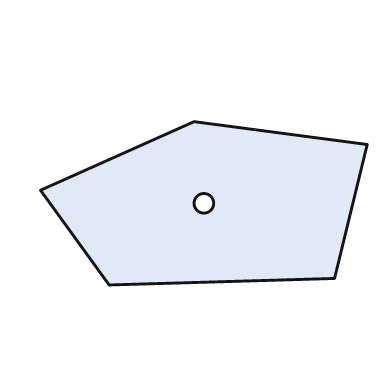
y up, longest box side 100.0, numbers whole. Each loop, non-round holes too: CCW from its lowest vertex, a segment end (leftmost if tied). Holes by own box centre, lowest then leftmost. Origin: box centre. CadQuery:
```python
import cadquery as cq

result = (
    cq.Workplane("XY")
    .moveTo(-29.0, -25.0)
    .lineTo(40.0, -23.0)
    .lineTo(50.0, 18.0)
    .lineTo(-3.0, 25.0)
    .lineTo(-50.0, 4.0)
    .close()
    .moveTo(0.0, 0.0)
    .circle(3.0)
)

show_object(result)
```